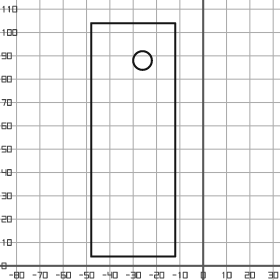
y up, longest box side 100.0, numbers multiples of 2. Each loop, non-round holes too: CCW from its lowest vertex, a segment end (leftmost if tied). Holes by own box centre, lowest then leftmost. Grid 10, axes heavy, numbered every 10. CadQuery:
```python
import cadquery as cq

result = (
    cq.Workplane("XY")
    .moveTo(-48.0, 4.0)
    .lineTo(-12.0, 4.0)
    .lineTo(-12.0, 104.0)
    .lineTo(-48.0, 104.0)
    .close()
    .moveTo(-26.0, 88.0)
    .circle(4.0)
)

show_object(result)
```